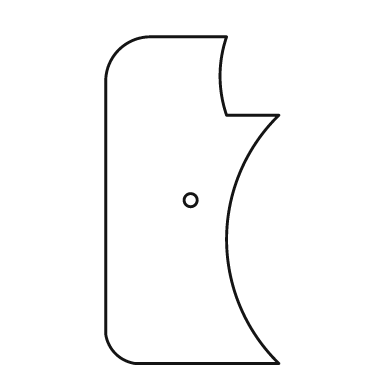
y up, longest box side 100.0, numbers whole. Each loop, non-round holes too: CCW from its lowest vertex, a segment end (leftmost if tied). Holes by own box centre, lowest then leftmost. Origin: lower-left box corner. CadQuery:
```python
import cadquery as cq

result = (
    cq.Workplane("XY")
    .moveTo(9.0, 0.0)
    .lineTo(53.0, 0.0)
    .threePointArc((37.0, 38.0), (53.0, 76.0))
    .lineTo(37.0, 76.0)
    .threePointArc((35.0, 88.0), (37.0, 100.0))
    .lineTo(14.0, 100.0)
    .threePointArc((4.0, 96.0), (0.0, 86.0))
    .lineTo(0.0, 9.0)
    .threePointArc((3.0, 3.0), (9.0, 0.0))
    .close()
    .moveTo(26.0, 50.0)
    .circle(2.0)
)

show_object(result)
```